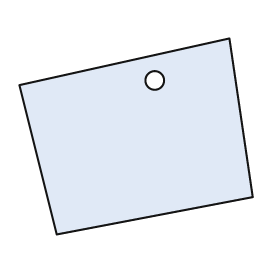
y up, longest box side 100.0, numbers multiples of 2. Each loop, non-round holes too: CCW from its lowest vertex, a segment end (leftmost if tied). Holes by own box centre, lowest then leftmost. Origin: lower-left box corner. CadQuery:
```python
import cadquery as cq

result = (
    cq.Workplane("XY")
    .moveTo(16.0, 0.0)
    .lineTo(100.0, 16.0)
    .lineTo(90.0, 84.0)
    .lineTo(0.0, 64.0)
    .close()
    .moveTo(58.0, 66.0)
    .circle(4.0)
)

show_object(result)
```